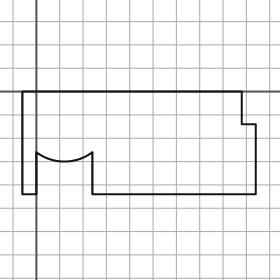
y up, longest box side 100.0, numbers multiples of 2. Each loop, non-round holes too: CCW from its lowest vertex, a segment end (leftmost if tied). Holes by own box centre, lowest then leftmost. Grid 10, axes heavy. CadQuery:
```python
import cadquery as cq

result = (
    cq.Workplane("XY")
    .moveTo(-6.0, -44.0)
    .lineTo(0.0, -44.0)
    .lineTo(0.0, -26.0)
    .threePointArc((12.0, -30.0), (24.0, -26.0))
    .lineTo(24.0, -44.0)
    .lineTo(94.0, -44.0)
    .lineTo(94.0, -14.0)
    .lineTo(88.0, -14.0)
    .lineTo(88.0, 0.0)
    .lineTo(-6.0, 0.0)
    .close()
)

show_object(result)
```